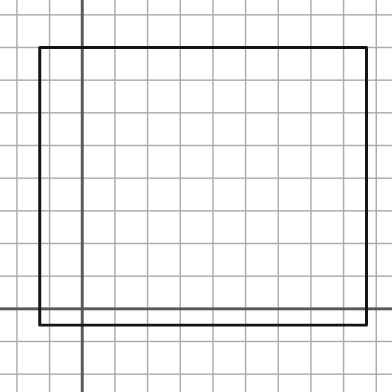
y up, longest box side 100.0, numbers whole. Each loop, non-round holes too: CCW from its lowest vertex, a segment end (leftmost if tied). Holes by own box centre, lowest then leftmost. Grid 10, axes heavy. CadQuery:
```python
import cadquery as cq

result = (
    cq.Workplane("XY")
    .moveTo(-13.0, -5.0)
    .lineTo(87.0, -5.0)
    .lineTo(87.0, 80.0)
    .lineTo(-13.0, 80.0)
    .close()
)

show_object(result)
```